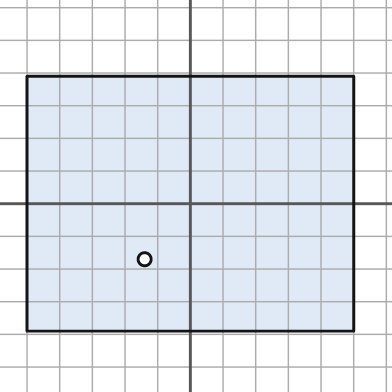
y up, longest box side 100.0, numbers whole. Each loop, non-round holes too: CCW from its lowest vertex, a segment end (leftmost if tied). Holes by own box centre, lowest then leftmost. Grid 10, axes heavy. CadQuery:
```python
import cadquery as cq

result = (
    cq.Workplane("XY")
    .moveTo(-50.0, -39.0)
    .lineTo(50.0, -39.0)
    .lineTo(50.0, 39.0)
    .lineTo(-50.0, 39.0)
    .close()
    .moveTo(-14.0, -17.0)
    .circle(2.0)
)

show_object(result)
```